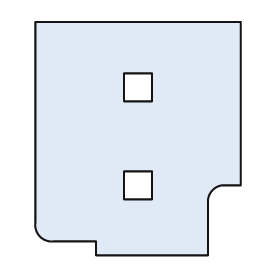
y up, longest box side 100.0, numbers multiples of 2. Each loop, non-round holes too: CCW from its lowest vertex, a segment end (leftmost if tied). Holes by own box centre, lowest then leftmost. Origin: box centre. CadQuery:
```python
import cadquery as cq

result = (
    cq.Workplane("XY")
    .moveTo(-18.0, -50.0)
    .lineTo(30.0, -50.0)
    .lineTo(30.0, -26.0)
    .threePointArc((32.0, -22.0), (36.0, -20.0))
    .lineTo(44.0, -20.0)
    .lineTo(44.0, 50.0)
    .lineTo(-44.0, 50.0)
    .lineTo(-44.0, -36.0)
    .threePointArc((-42.0, -42.0), (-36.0, -44.0))
    .lineTo(-18.0, -44.0)
    .close()
    .moveTo(-6.0, -26.0)
    .lineTo(6.0, -26.0)
    .lineTo(6.0, -14.0)
    .lineTo(-6.0, -14.0)
    .close()
    .moveTo(-6.0, 16.0)
    .lineTo(6.0, 16.0)
    .lineTo(6.0, 28.0)
    .lineTo(-6.0, 28.0)
    .close()
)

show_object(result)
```